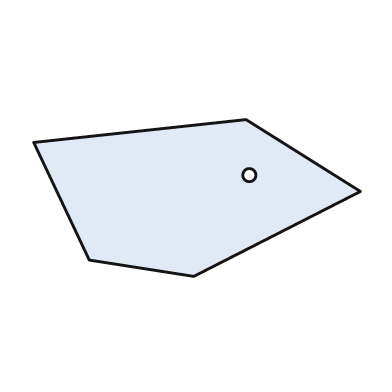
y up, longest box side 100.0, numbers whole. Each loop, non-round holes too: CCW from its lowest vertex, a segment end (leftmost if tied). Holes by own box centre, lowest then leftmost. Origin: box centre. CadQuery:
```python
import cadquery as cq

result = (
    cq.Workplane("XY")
    .moveTo(-1.0, -24.0)
    .lineTo(50.0, 2.0)
    .lineTo(15.0, 24.0)
    .lineTo(-50.0, 17.0)
    .lineTo(-33.0, -19.0)
    .close()
    .moveTo(16.0, 7.0)
    .circle(2.0)
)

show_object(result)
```